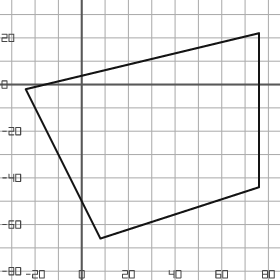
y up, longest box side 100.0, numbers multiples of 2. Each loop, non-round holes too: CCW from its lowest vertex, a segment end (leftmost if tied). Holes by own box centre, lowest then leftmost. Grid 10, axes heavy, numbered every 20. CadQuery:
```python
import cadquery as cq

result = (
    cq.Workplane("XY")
    .moveTo(8.0, -66.0)
    .lineTo(76.0, -44.0)
    .lineTo(76.0, 22.0)
    .lineTo(-24.0, -2.0)
    .close()
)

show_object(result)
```